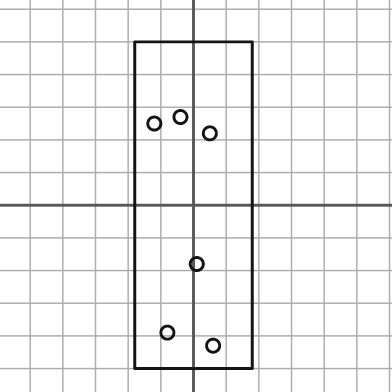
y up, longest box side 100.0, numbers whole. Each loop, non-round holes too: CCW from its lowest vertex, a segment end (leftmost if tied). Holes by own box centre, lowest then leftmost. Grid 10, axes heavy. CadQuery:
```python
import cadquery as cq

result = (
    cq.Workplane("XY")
    .moveTo(-18.0, -50.0)
    .lineTo(18.0, -50.0)
    .lineTo(18.0, 50.0)
    .lineTo(-18.0, 50.0)
    .close()
    .moveTo(6.0, -43.0)
    .circle(2.0)
    .moveTo(-8.0, -39.0)
    .circle(2.0)
    .moveTo(1.0, -18.0)
    .circle(2.0)
    .moveTo(5.0, 22.0)
    .circle(2.0)
    .moveTo(-12.0, 25.0)
    .circle(2.0)
    .moveTo(-4.0, 27.0)
    .circle(2.0)
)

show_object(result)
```